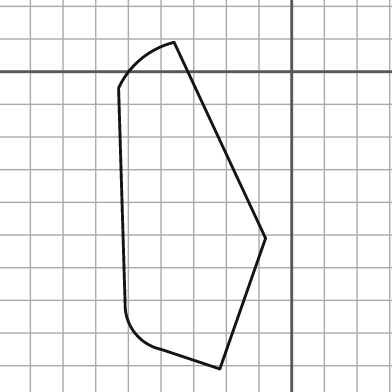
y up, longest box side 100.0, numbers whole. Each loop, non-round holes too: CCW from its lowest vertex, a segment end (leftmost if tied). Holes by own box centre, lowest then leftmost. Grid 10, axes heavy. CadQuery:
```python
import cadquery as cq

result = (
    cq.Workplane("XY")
    .moveTo(-22.0, -91.0)
    .lineTo(-8.0, -51.0)
    .lineTo(-36.0, 9.0)
    .threePointArc((-46.0, 4.0), (-53.0, -5.0))
    .lineTo(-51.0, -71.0)
    .threePointArc((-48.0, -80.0), (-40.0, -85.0))
    .close()
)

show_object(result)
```